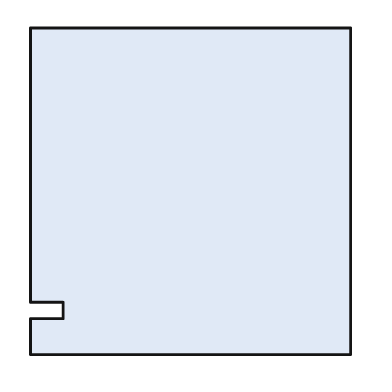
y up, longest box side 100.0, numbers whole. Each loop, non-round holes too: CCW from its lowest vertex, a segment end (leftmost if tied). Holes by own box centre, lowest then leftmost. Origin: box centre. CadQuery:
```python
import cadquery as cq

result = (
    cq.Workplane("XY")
    .moveTo(-49.0, -50.0)
    .lineTo(49.0, -50.0)
    .lineTo(49.0, 50.0)
    .lineTo(-49.0, 50.0)
    .lineTo(-49.0, -34.0)
    .lineTo(-39.0, -34.0)
    .lineTo(-39.0, -39.0)
    .lineTo(-49.0, -39.0)
    .close()
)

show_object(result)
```